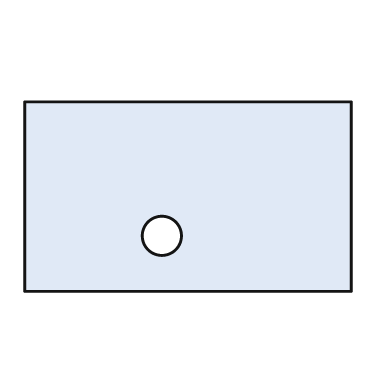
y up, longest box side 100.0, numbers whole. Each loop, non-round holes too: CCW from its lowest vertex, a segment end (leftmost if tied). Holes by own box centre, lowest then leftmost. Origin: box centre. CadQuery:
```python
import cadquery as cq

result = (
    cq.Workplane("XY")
    .moveTo(-50.0, -29.0)
    .lineTo(50.0, -29.0)
    .lineTo(50.0, 29.0)
    .lineTo(-50.0, 29.0)
    .close()
    .moveTo(-8.0, -12.0)
    .circle(6.0)
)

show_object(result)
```